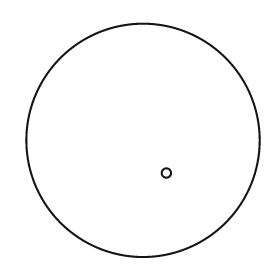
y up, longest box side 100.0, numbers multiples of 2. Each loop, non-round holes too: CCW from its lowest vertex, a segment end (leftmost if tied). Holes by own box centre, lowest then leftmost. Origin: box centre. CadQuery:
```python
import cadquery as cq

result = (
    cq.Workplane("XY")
    .moveTo(0.0, 0.0)
    .circle(50.0)
    .moveTo(10.0, -14.0)
    .circle(2.0)
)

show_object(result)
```